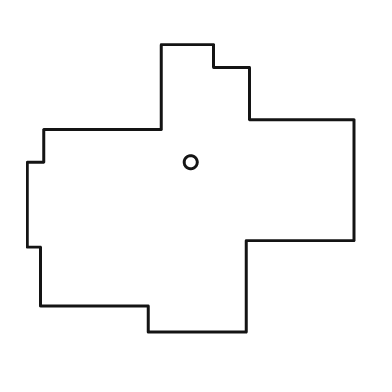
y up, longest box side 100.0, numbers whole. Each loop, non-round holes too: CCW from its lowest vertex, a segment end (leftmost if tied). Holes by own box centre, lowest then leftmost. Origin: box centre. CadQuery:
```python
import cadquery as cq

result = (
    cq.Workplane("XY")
    .moveTo(-13.0, -44.0)
    .lineTo(17.0, -44.0)
    .lineTo(17.0, -16.0)
    .lineTo(50.0, -16.0)
    .lineTo(50.0, 21.0)
    .lineTo(18.0, 21.0)
    .lineTo(18.0, 37.0)
    .lineTo(7.0, 37.0)
    .lineTo(7.0, 44.0)
    .lineTo(-9.0, 44.0)
    .lineTo(-9.0, 18.0)
    .lineTo(-45.0, 18.0)
    .lineTo(-45.0, 8.0)
    .lineTo(-50.0, 8.0)
    .lineTo(-50.0, -18.0)
    .lineTo(-46.0, -18.0)
    .lineTo(-46.0, -36.0)
    .lineTo(-13.0, -36.0)
    .close()
    .moveTo(0.0, 8.0)
    .circle(2.0)
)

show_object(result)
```